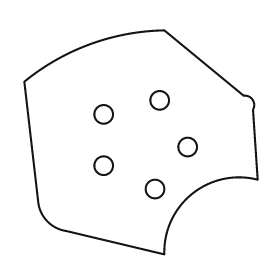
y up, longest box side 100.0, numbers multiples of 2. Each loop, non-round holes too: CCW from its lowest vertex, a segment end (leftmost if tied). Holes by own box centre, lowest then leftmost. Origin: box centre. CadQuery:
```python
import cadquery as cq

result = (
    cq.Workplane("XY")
    .moveTo(10.0, -48.0)
    .threePointArc((22.0, -22.0), (50.0, -16.0))
    .lineTo(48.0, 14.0)
    .threePointArc((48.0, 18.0), (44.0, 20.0))
    .lineTo(10.0, 48.0)
    .threePointArc((-22.0, 42.0), (-50.0, 26.0))
    .lineTo(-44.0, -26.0)
    .threePointArc((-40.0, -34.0), (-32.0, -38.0))
    .close()
    .moveTo(6.0, -20.0)
    .circle(4.0)
    .moveTo(-16.0, -10.0)
    .circle(4.0)
    .moveTo(20.0, -2.0)
    .circle(4.0)
    .moveTo(-16.0, 12.0)
    .circle(4.0)
    .moveTo(8.0, 18.0)
    .circle(4.0)
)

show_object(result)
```